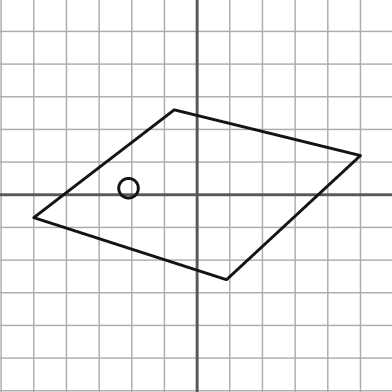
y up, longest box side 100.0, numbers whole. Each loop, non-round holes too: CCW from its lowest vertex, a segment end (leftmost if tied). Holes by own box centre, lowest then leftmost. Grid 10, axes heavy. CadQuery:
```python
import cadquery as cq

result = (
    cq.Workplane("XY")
    .moveTo(9.0, -26.0)
    .lineTo(50.0, 12.0)
    .lineTo(-7.0, 26.0)
    .lineTo(-50.0, -7.0)
    .close()
    .moveTo(-21.0, 2.0)
    .circle(3.0)
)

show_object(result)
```